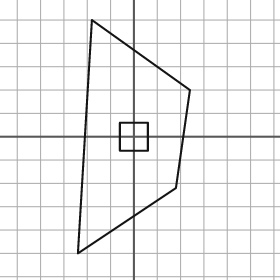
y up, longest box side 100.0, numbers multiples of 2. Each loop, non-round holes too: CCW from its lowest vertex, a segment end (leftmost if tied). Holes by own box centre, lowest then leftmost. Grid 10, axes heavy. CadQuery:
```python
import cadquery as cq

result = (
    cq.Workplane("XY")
    .moveTo(-24.0, -50.0)
    .lineTo(18.0, -22.0)
    .lineTo(24.0, 20.0)
    .lineTo(-18.0, 50.0)
    .close()
    .moveTo(-6.0, -6.0)
    .lineTo(6.0, -6.0)
    .lineTo(6.0, 6.0)
    .lineTo(-6.0, 6.0)
    .close()
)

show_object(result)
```